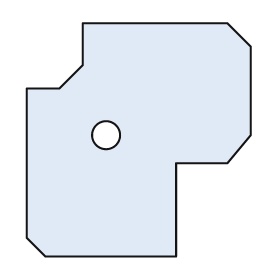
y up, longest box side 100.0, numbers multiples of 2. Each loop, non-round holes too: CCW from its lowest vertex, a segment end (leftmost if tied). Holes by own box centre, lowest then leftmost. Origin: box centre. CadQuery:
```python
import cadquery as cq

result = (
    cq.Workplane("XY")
    .moveTo(-40.0, -50.0)
    .lineTo(16.0, -50.0)
    .lineTo(16.0, -10.0)
    .lineTo(38.0, -10.0)
    .lineTo(48.0, 2.0)
    .lineTo(48.0, 40.0)
    .lineTo(38.0, 50.0)
    .lineTo(-24.0, 50.0)
    .lineTo(-24.0, 32.0)
    .lineTo(-34.0, 22.0)
    .lineTo(-48.0, 22.0)
    .lineTo(-48.0, -42.0)
    .close()
    .moveTo(-14.0, 2.0)
    .circle(6.0)
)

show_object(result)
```